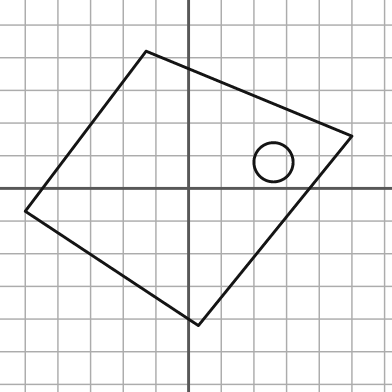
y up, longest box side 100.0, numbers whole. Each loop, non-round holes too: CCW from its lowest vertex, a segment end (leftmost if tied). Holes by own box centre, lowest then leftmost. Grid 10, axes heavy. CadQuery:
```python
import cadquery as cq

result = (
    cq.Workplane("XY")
    .moveTo(3.0, -42.0)
    .lineTo(50.0, 16.0)
    .lineTo(-13.0, 42.0)
    .lineTo(-50.0, -7.0)
    .close()
    .moveTo(26.0, 8.0)
    .circle(6.0)
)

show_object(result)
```